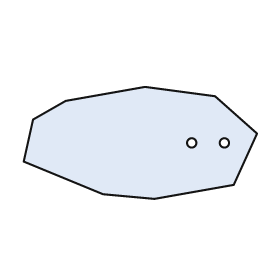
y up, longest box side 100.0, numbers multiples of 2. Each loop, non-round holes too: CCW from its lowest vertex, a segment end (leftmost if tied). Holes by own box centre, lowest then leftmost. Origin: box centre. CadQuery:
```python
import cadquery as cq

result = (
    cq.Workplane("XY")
    .moveTo(6.0, -24.0)
    .lineTo(40.0, -18.0)
    .lineTo(50.0, 4.0)
    .lineTo(32.0, 20.0)
    .lineTo(2.0, 24.0)
    .lineTo(-32.0, 18.0)
    .lineTo(-46.0, 10.0)
    .lineTo(-50.0, -8.0)
    .lineTo(-16.0, -22.0)
    .close()
    .moveTo(22.0, 0.0)
    .circle(2.0)
    .moveTo(36.0, 0.0)
    .circle(2.0)
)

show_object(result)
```